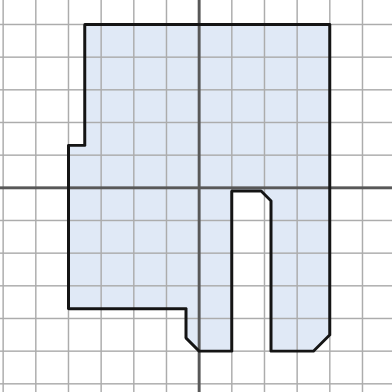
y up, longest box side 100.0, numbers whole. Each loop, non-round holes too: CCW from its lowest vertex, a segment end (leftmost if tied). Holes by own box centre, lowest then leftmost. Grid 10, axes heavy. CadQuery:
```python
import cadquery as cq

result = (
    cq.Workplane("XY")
    .moveTo(0.0, -50.0)
    .lineTo(10.0, -50.0)
    .lineTo(10.0, -1.0)
    .lineTo(19.0, -1.0)
    .lineTo(22.0, -4.0)
    .lineTo(22.0, -50.0)
    .lineTo(35.0, -50.0)
    .lineTo(40.0, -45.0)
    .lineTo(40.0, 50.0)
    .lineTo(-35.0, 50.0)
    .lineTo(-35.0, 13.0)
    .lineTo(-40.0, 13.0)
    .lineTo(-40.0, -37.0)
    .lineTo(-4.0, -37.0)
    .lineTo(-4.0, -46.0)
    .close()
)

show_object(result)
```